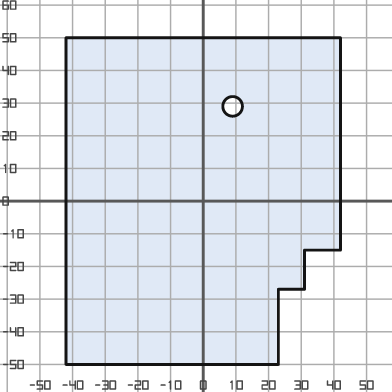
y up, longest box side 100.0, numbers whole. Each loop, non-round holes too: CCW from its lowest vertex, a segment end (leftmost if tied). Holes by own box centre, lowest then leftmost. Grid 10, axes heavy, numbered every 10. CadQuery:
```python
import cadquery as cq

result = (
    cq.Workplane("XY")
    .moveTo(-42.0, -50.0)
    .lineTo(23.0, -50.0)
    .lineTo(23.0, -27.0)
    .lineTo(31.0, -27.0)
    .lineTo(31.0, -15.0)
    .lineTo(42.0, -15.0)
    .lineTo(42.0, 50.0)
    .lineTo(-42.0, 50.0)
    .close()
    .moveTo(9.0, 29.0)
    .circle(3.0)
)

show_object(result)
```